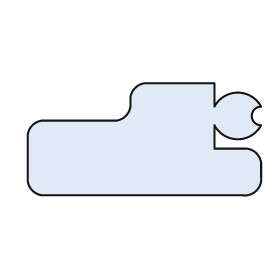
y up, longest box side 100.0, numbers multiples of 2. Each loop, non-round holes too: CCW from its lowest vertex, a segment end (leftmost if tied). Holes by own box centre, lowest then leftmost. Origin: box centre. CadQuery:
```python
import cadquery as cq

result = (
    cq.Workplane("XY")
    .moveTo(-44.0, -24.0)
    .lineTo(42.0, -24.0)
    .threePointArc((48.0, -22.0), (50.0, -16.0))
    .lineTo(50.0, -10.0)
    .threePointArc((48.0, -6.0), (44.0, -4.0))
    .lineTo(30.0, -4.0)
    .lineTo(30.0, 6.0)
    .threePointArc((40.0, 0.0), (50.0, 6.0))
    .threePointArc((46.0, 10.0), (50.0, 14.0))
    .threePointArc((40.0, 20.0), (30.0, 14.0))
    .lineTo(30.0, 24.0)
    .lineTo(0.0, 24.0)
    .threePointArc((-4.0, 22.0), (-6.0, 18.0))
    .lineTo(-6.0, 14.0)
    .threePointArc((-8.0, 10.0), (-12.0, 8.0))
    .lineTo(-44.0, 8.0)
    .threePointArc((-48.0, 6.0), (-50.0, 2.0))
    .lineTo(-50.0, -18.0)
    .threePointArc((-48.0, -22.0), (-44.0, -24.0))
    .close()
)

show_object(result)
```